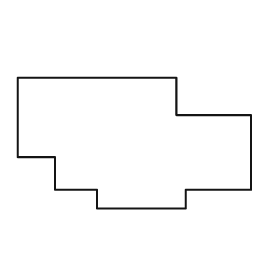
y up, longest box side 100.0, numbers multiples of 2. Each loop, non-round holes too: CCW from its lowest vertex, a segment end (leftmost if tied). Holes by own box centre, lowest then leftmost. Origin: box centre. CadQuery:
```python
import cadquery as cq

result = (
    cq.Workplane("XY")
    .moveTo(-16.0, -28.0)
    .lineTo(22.0, -28.0)
    .lineTo(22.0, -20.0)
    .lineTo(50.0, -20.0)
    .lineTo(50.0, 12.0)
    .lineTo(18.0, 12.0)
    .lineTo(18.0, 28.0)
    .lineTo(-50.0, 28.0)
    .lineTo(-50.0, -6.0)
    .lineTo(-34.0, -6.0)
    .lineTo(-34.0, -20.0)
    .lineTo(-16.0, -20.0)
    .close()
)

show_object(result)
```